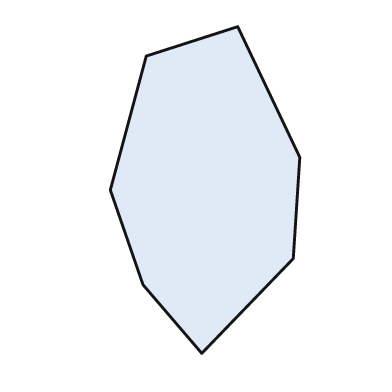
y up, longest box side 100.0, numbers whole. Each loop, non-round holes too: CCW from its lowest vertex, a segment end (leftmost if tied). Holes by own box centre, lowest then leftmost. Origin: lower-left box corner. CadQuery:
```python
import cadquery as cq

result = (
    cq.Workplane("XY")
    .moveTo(28.0, 0.0)
    .lineTo(56.0, 29.0)
    .lineTo(58.0, 60.0)
    .lineTo(39.0, 100.0)
    .lineTo(11.0, 91.0)
    .lineTo(0.0, 50.0)
    .lineTo(10.0, 21.0)
    .close()
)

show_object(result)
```